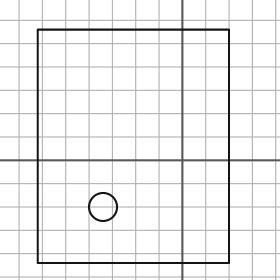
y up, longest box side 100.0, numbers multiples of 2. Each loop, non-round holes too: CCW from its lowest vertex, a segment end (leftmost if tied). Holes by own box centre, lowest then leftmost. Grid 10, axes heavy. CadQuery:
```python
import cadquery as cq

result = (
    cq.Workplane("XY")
    .moveTo(-62.0, -44.0)
    .lineTo(20.0, -44.0)
    .lineTo(20.0, 56.0)
    .lineTo(-62.0, 56.0)
    .close()
    .moveTo(-34.0, -20.0)
    .circle(6.0)
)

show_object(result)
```